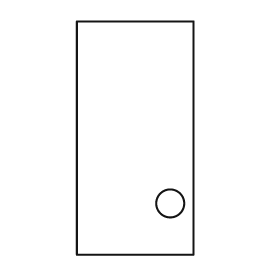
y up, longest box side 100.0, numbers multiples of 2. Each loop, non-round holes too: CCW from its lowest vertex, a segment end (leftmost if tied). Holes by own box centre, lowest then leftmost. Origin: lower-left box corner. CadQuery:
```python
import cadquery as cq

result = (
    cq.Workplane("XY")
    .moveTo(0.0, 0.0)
    .lineTo(50.0, 0.0)
    .lineTo(50.0, 100.0)
    .lineTo(0.0, 100.0)
    .close()
    .moveTo(40.0, 22.0)
    .circle(6.0)
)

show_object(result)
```